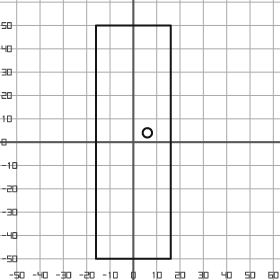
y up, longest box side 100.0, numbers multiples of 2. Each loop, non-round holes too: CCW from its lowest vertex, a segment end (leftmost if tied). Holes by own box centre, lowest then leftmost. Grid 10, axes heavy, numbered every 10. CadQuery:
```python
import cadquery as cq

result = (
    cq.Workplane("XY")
    .moveTo(-16.0, -50.0)
    .lineTo(16.0, -50.0)
    .lineTo(16.0, 50.0)
    .lineTo(-16.0, 50.0)
    .close()
    .moveTo(6.0, 4.0)
    .circle(2.0)
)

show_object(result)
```